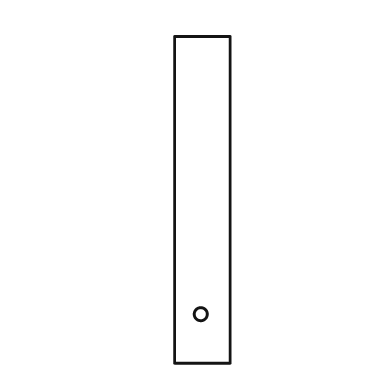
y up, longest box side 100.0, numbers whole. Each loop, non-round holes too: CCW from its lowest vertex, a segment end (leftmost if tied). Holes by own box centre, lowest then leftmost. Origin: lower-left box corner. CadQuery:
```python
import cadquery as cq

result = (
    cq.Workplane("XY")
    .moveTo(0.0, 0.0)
    .lineTo(17.0, 0.0)
    .lineTo(17.0, 100.0)
    .lineTo(0.0, 100.0)
    .close()
    .moveTo(8.0, 15.0)
    .circle(2.0)
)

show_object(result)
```